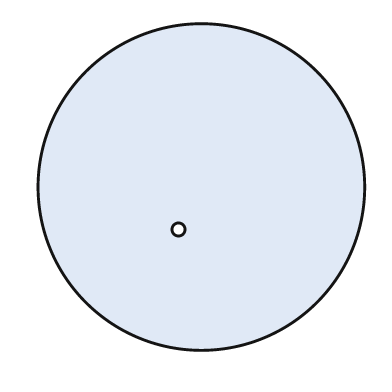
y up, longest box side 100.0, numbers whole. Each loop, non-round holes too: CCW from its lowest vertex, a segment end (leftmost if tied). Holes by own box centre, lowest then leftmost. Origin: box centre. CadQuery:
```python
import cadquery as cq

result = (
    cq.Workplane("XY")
    .moveTo(0.0, 0.0)
    .circle(50.0)
    .moveTo(-7.0, -13.0)
    .circle(2.0)
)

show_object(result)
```